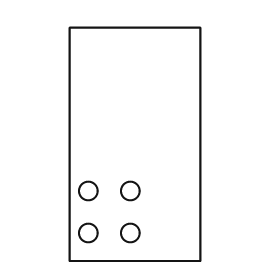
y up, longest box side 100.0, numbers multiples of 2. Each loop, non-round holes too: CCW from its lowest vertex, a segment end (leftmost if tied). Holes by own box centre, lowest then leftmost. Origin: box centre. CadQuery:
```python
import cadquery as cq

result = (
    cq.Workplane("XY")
    .moveTo(-28.0, -50.0)
    .lineTo(28.0, -50.0)
    .lineTo(28.0, 50.0)
    .lineTo(-28.0, 50.0)
    .close()
    .moveTo(-20.0, -38.0)
    .circle(4.0)
    .moveTo(-2.0, -38.0)
    .circle(4.0)
    .moveTo(-20.0, -20.0)
    .circle(4.0)
    .moveTo(-2.0, -20.0)
    .circle(4.0)
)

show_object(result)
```